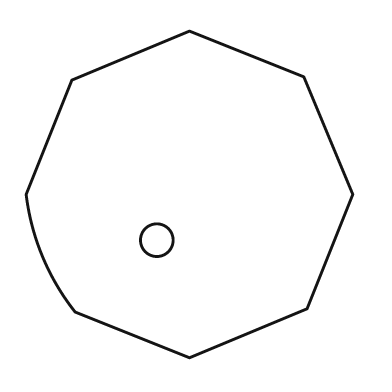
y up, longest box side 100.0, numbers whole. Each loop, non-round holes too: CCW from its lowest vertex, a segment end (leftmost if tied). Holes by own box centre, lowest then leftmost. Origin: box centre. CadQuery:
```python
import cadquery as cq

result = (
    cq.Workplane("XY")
    .moveTo(0.0, -50.0)
    .lineTo(36.0, -35.0)
    .lineTo(50.0, 0.0)
    .lineTo(35.0, 36.0)
    .lineTo(0.0, 50.0)
    .lineTo(-36.0, 35.0)
    .lineTo(-50.0, 0.0)
    .threePointArc((-45.0, -19.0), (-35.0, -36.0))
    .close()
    .moveTo(-10.0, -14.0)
    .circle(5.0)
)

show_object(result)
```